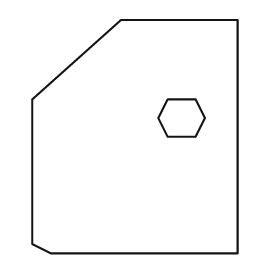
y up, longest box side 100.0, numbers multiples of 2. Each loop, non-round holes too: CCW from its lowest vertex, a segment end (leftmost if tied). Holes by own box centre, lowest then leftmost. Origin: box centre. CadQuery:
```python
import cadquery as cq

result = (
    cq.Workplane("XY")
    .moveTo(-36.0, -50.0)
    .lineTo(44.0, -50.0)
    .lineTo(44.0, 50.0)
    .lineTo(-6.0, 50.0)
    .lineTo(-44.0, 16.0)
    .lineTo(-44.0, -46.0)
    .close()
    .moveTo(14.0, 0.0)
    .lineTo(26.0, 0.0)
    .lineTo(30.0, 8.0)
    .lineTo(26.0, 16.0)
    .lineTo(14.0, 16.0)
    .lineTo(10.0, 8.0)
    .close()
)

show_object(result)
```